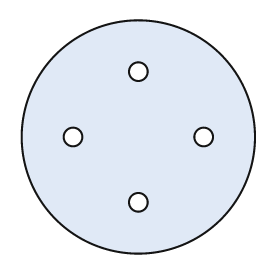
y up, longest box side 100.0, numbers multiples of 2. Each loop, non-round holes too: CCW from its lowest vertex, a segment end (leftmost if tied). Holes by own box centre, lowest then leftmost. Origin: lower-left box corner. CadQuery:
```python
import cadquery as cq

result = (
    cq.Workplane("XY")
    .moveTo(50.0, 50.0)
    .circle(50.0)
    .moveTo(50.0, 22.0)
    .circle(4.0)
    .moveTo(22.0, 50.0)
    .circle(4.0)
    .moveTo(78.0, 50.0)
    .circle(4.0)
    .moveTo(50.0, 78.0)
    .circle(4.0)
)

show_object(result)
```